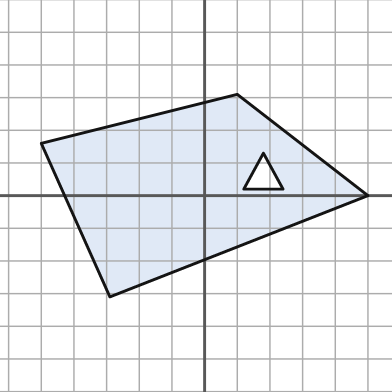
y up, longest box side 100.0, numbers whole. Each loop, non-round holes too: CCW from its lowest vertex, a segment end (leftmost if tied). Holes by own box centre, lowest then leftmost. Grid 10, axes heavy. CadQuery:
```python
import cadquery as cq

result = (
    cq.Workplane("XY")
    .moveTo(-29.0, -31.0)
    .lineTo(50.0, 0.0)
    .lineTo(10.0, 31.0)
    .lineTo(-50.0, 16.0)
    .close()
    .moveTo(12.0, 2.0)
    .lineTo(24.0, 2.0)
    .lineTo(18.0, 13.0)
    .close()
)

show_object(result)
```